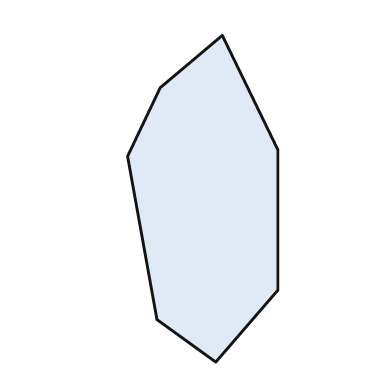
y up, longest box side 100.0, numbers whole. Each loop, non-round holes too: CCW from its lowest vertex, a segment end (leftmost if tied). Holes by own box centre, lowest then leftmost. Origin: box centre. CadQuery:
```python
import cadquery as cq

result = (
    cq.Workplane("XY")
    .moveTo(4.0, -50.0)
    .lineTo(23.0, -28.0)
    .lineTo(23.0, 15.0)
    .lineTo(6.0, 50.0)
    .lineTo(-13.0, 34.0)
    .lineTo(-23.0, 13.0)
    .lineTo(-14.0, -37.0)
    .close()
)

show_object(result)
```